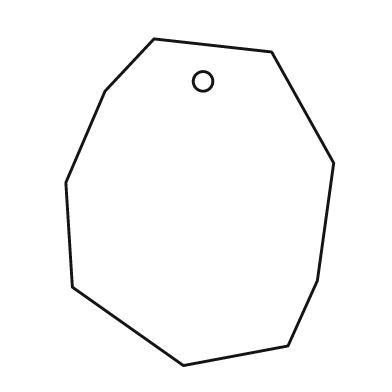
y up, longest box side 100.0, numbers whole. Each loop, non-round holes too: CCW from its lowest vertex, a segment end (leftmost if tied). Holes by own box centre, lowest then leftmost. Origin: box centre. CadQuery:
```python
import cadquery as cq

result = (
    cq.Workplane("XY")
    .moveTo(-5.0, -50.0)
    .lineTo(27.0, -44.0)
    .lineTo(36.0, -24.0)
    .lineTo(41.0, 12.0)
    .lineTo(22.0, 46.0)
    .lineTo(-14.0, 50.0)
    .lineTo(-29.0, 34.0)
    .lineTo(-41.0, 6.0)
    .lineTo(-39.0, -26.0)
    .close()
    .moveTo(1.0, 37.0)
    .circle(3.0)
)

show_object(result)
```